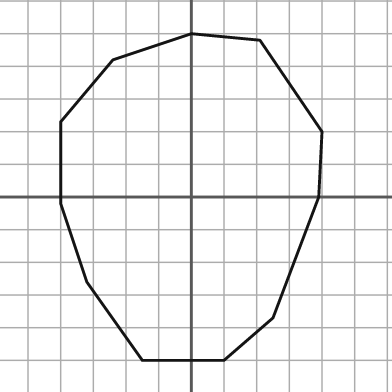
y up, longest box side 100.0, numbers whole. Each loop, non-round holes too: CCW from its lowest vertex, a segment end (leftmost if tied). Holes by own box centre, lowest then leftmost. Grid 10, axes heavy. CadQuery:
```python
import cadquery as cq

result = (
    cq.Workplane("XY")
    .moveTo(-15.0, -50.0)
    .lineTo(10.0, -50.0)
    .lineTo(25.0, -37.0)
    .lineTo(39.0, 0.0)
    .lineTo(40.0, 20.0)
    .lineTo(21.0, 48.0)
    .lineTo(0.0, 50.0)
    .lineTo(-24.0, 42.0)
    .lineTo(-40.0, 23.0)
    .lineTo(-40.0, -2.0)
    .lineTo(-32.0, -26.0)
    .close()
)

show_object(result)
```